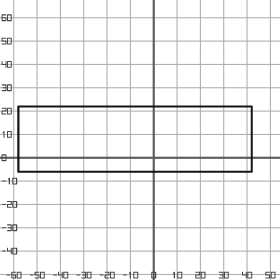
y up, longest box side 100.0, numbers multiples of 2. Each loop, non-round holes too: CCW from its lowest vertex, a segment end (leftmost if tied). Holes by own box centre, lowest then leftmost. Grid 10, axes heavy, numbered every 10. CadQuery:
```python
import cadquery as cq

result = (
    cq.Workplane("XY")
    .moveTo(-58.0, -6.0)
    .lineTo(42.0, -6.0)
    .lineTo(42.0, 22.0)
    .lineTo(-58.0, 22.0)
    .close()
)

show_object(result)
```